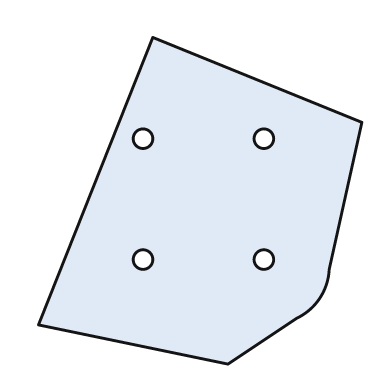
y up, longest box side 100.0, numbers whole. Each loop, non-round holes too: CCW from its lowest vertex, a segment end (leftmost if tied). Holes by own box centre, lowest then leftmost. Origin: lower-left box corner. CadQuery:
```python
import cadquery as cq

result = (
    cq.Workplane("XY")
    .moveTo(58.0, 0.0)
    .lineTo(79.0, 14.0)
    .threePointArc((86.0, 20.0), (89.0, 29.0))
    .lineTo(99.0, 74.0)
    .lineTo(35.0, 100.0)
    .lineTo(0.0, 12.0)
    .close()
    .moveTo(32.0, 32.0)
    .circle(3.0)
    .moveTo(69.0, 32.0)
    .circle(3.0)
    .moveTo(32.0, 69.0)
    .circle(3.0)
    .moveTo(69.0, 69.0)
    .circle(3.0)
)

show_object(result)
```